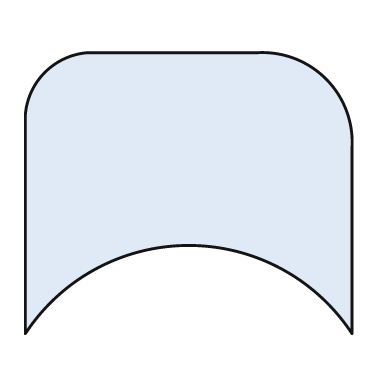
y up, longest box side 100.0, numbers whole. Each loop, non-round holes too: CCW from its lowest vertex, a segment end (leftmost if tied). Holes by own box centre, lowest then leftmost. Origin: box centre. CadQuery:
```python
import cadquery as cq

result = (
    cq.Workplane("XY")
    .moveTo(-50.0, -43.0)
    .threePointArc((0.0, -16.0), (50.0, -43.0))
    .lineTo(50.0, 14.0)
    .threePointArc((42.0, 35.0), (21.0, 43.0))
    .lineTo(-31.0, 43.0)
    .threePointArc((-44.0, 37.0), (-50.0, 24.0))
    .close()
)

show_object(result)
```